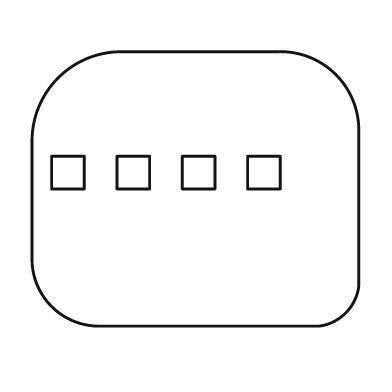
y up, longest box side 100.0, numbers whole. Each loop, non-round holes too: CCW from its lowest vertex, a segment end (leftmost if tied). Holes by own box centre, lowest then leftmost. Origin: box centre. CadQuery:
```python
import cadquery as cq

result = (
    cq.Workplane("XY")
    .moveTo(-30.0, -42.0)
    .lineTo(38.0, -42.0)
    .threePointArc((46.0, -38.0), (50.0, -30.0))
    .lineTo(50.0, 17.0)
    .threePointArc((43.0, 35.0), (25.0, 42.0))
    .lineTo(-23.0, 42.0)
    .threePointArc((-42.0, 34.0), (-50.0, 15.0))
    .lineTo(-50.0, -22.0)
    .threePointArc((-44.0, -36.0), (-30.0, -42.0))
    .close()
    .moveTo(-44.0, 0.0)
    .lineTo(-34.0, 0.0)
    .lineTo(-34.0, 10.0)
    .lineTo(-44.0, 10.0)
    .close()
    .moveTo(-24.0, 0.0)
    .lineTo(-14.0, 0.0)
    .lineTo(-14.0, 10.0)
    .lineTo(-24.0, 10.0)
    .close()
    .moveTo(-4.0, 0.0)
    .lineTo(6.0, 0.0)
    .lineTo(6.0, 10.0)
    .lineTo(-4.0, 10.0)
    .close()
    .moveTo(16.0, 0.0)
    .lineTo(26.0, 0.0)
    .lineTo(26.0, 10.0)
    .lineTo(16.0, 10.0)
    .close()
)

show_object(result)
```